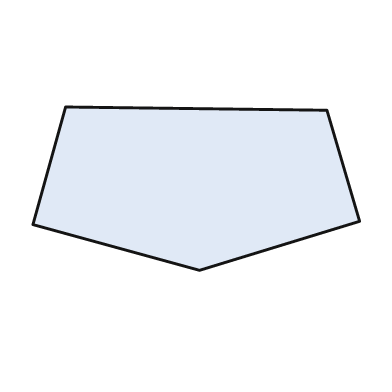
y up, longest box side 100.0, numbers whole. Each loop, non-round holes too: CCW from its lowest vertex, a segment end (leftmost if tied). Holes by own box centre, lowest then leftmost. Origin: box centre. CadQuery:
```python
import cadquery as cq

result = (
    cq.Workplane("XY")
    .moveTo(1.0, -25.0)
    .lineTo(50.0, -10.0)
    .lineTo(40.0, 24.0)
    .lineTo(-40.0, 25.0)
    .lineTo(-50.0, -11.0)
    .close()
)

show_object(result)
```